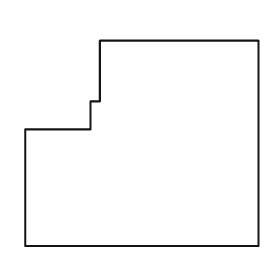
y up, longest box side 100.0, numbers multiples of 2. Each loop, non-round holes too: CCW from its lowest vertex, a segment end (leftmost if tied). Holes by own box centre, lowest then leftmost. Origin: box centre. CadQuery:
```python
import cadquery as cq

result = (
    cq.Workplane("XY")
    .moveTo(-50.0, -44.0)
    .lineTo(50.0, -44.0)
    .lineTo(50.0, 44.0)
    .lineTo(-18.0, 44.0)
    .lineTo(-18.0, 18.0)
    .lineTo(-22.0, 18.0)
    .lineTo(-22.0, 6.0)
    .lineTo(-50.0, 6.0)
    .close()
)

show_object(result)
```